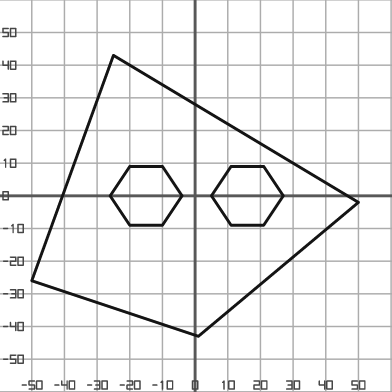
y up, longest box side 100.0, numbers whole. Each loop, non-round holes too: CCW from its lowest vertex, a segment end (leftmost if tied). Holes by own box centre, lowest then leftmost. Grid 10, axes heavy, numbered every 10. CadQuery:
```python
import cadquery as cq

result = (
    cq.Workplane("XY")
    .moveTo(1.0, -43.0)
    .lineTo(50.0, -2.0)
    .lineTo(-25.0, 43.0)
    .lineTo(-50.0, -26.0)
    .close()
    .moveTo(-20.0, -9.0)
    .lineTo(-10.0, -9.0)
    .lineTo(-4.0, 0.0)
    .lineTo(-10.0, 9.0)
    .lineTo(-20.0, 9.0)
    .lineTo(-26.0, 0.0)
    .close()
    .moveTo(11.0, -9.0)
    .lineTo(21.0, -9.0)
    .lineTo(27.0, 0.0)
    .lineTo(21.0, 9.0)
    .lineTo(11.0, 9.0)
    .lineTo(5.0, 0.0)
    .close()
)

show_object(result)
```